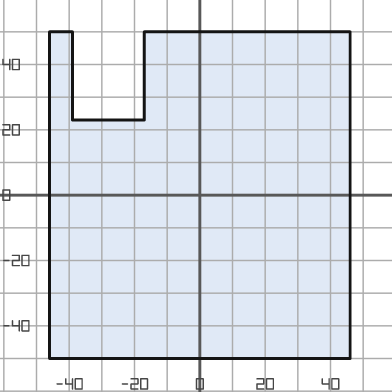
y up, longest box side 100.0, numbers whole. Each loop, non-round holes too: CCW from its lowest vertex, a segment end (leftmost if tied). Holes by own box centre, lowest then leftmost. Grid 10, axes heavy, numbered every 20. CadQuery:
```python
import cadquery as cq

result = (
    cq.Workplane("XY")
    .moveTo(-46.0, -50.0)
    .lineTo(46.0, -50.0)
    .lineTo(46.0, 50.0)
    .lineTo(-17.0, 50.0)
    .lineTo(-17.0, 23.0)
    .lineTo(-39.0, 23.0)
    .lineTo(-39.0, 50.0)
    .lineTo(-46.0, 50.0)
    .close()
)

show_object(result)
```